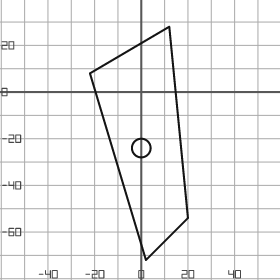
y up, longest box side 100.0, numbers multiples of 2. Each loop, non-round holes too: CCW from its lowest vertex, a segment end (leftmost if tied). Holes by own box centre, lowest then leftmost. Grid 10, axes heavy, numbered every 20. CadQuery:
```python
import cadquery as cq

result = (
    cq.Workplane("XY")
    .moveTo(2.0, -72.0)
    .lineTo(20.0, -54.0)
    .lineTo(12.0, 28.0)
    .lineTo(-22.0, 8.0)
    .close()
    .moveTo(0.0, -24.0)
    .circle(4.0)
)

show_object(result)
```